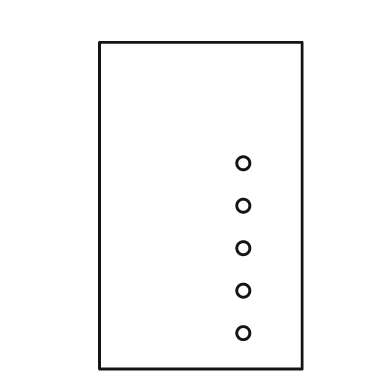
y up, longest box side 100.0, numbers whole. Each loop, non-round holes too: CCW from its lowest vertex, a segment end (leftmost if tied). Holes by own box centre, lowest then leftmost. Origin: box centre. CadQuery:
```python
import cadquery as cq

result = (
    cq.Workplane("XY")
    .moveTo(-31.0, -50.0)
    .lineTo(31.0, -50.0)
    .lineTo(31.0, 50.0)
    .lineTo(-31.0, 50.0)
    .close()
    .moveTo(13.0, -39.0)
    .circle(2.0)
    .moveTo(13.0, -26.0)
    .circle(2.0)
    .moveTo(13.0, -13.0)
    .circle(2.0)
    .moveTo(13.0, 0.0)
    .circle(2.0)
    .moveTo(13.0, 13.0)
    .circle(2.0)
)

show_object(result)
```